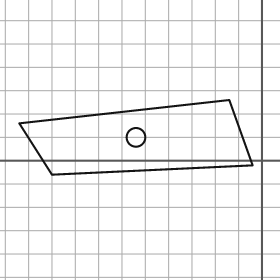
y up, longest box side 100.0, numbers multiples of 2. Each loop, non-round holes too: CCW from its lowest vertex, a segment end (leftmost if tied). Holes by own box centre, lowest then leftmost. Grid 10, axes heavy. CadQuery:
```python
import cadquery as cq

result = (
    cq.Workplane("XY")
    .moveTo(-90.0, -6.0)
    .lineTo(-4.0, -2.0)
    .lineTo(-14.0, 26.0)
    .lineTo(-104.0, 16.0)
    .close()
    .moveTo(-54.0, 10.0)
    .circle(4.0)
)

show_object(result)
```